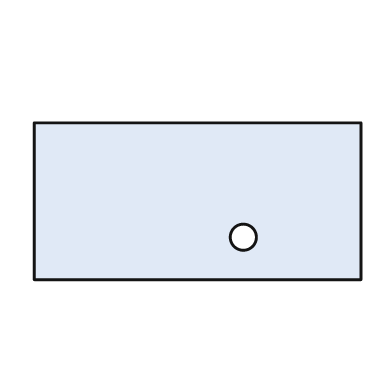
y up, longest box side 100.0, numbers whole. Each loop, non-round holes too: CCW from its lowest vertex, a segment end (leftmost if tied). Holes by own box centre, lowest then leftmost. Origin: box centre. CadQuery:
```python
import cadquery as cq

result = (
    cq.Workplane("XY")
    .moveTo(-50.0, -24.0)
    .lineTo(50.0, -24.0)
    .lineTo(50.0, 24.0)
    .lineTo(-50.0, 24.0)
    .close()
    .moveTo(14.0, -11.0)
    .circle(4.0)
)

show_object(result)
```